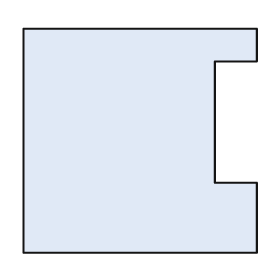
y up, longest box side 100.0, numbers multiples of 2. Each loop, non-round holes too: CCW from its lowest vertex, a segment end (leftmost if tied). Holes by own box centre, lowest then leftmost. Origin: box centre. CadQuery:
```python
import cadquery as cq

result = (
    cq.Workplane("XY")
    .moveTo(-50.0, -48.0)
    .lineTo(50.0, -48.0)
    .lineTo(50.0, -18.0)
    .lineTo(32.0, -18.0)
    .lineTo(32.0, 34.0)
    .lineTo(50.0, 34.0)
    .lineTo(50.0, 48.0)
    .lineTo(-50.0, 48.0)
    .close()
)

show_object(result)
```